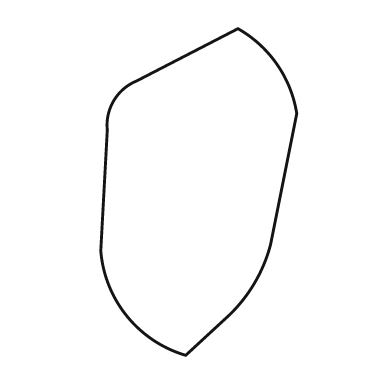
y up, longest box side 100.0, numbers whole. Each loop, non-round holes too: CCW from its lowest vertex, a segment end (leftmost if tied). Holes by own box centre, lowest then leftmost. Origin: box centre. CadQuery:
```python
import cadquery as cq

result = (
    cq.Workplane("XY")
    .moveTo(-4.0, -50.0)
    .lineTo(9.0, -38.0)
    .threePointArc((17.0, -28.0), (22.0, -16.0))
    .lineTo(30.0, 24.0)
    .threePointArc((24.0, 39.0), (12.0, 50.0))
    .lineTo(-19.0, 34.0)
    .threePointArc((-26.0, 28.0), (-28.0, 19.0))
    .lineTo(-30.0, -18.0)
    .threePointArc((-22.0, -38.0), (-4.0, -50.0))
    .close()
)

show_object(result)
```